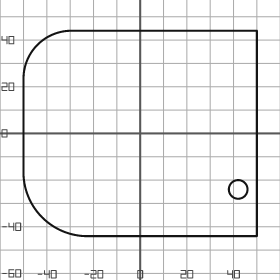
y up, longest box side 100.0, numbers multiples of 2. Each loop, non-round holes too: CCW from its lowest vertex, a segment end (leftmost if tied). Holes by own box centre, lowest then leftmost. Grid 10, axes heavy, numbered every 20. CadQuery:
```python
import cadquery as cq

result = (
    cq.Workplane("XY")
    .moveTo(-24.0, -44.0)
    .lineTo(50.0, -44.0)
    .lineTo(50.0, 44.0)
    .lineTo(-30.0, 44.0)
    .threePointArc((-44.0, 38.0), (-50.0, 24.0))
    .lineTo(-50.0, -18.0)
    .threePointArc((-42.0, -36.0), (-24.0, -44.0))
    .close()
    .moveTo(42.0, -24.0)
    .circle(4.0)
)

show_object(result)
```